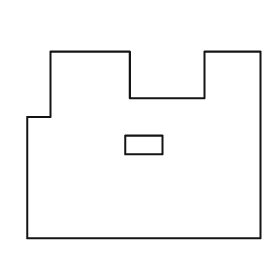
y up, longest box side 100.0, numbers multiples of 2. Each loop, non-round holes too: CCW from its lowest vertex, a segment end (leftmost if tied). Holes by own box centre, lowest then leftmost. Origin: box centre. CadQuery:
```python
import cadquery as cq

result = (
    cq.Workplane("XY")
    .moveTo(-50.0, -40.0)
    .lineTo(50.0, -40.0)
    .lineTo(50.0, 40.0)
    .lineTo(26.0, 40.0)
    .lineTo(26.0, 20.0)
    .lineTo(-6.0, 20.0)
    .lineTo(-6.0, 40.0)
    .lineTo(-40.0, 40.0)
    .lineTo(-40.0, 12.0)
    .lineTo(-50.0, 12.0)
    .close()
    .moveTo(-8.0, -4.0)
    .lineTo(8.0, -4.0)
    .lineTo(8.0, 4.0)
    .lineTo(-8.0, 4.0)
    .close()
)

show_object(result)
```